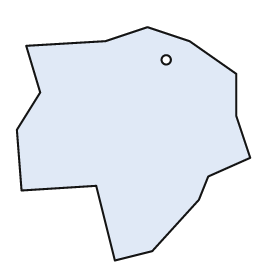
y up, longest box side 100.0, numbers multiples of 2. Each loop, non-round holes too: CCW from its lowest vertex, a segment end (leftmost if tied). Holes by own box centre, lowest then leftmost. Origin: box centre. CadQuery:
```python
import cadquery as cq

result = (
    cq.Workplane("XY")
    .moveTo(-8.0, -50.0)
    .lineTo(8.0, -46.0)
    .lineTo(28.0, -24.0)
    .lineTo(32.0, -14.0)
    .lineTo(50.0, -6.0)
    .lineTo(44.0, 12.0)
    .lineTo(44.0, 30.0)
    .lineTo(24.0, 44.0)
    .lineTo(6.0, 50.0)
    .lineTo(-12.0, 44.0)
    .lineTo(-46.0, 42.0)
    .lineTo(-40.0, 22.0)
    .lineTo(-50.0, 6.0)
    .lineTo(-48.0, -20.0)
    .lineTo(-16.0, -18.0)
    .close()
    .moveTo(14.0, 36.0)
    .circle(2.0)
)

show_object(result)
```